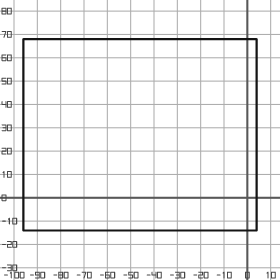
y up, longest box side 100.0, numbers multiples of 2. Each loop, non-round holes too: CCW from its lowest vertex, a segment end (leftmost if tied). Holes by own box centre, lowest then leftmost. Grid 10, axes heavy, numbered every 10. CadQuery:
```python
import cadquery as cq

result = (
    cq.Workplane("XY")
    .moveTo(-96.0, -14.0)
    .lineTo(4.0, -14.0)
    .lineTo(4.0, 68.0)
    .lineTo(-96.0, 68.0)
    .close()
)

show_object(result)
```